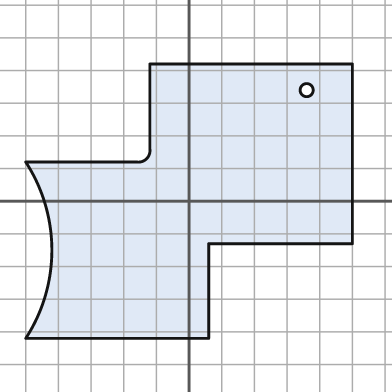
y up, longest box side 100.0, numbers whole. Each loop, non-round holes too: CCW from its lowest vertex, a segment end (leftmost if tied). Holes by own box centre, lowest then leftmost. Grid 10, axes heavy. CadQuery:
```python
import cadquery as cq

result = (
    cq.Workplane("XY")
    .moveTo(-50.0, -42.0)
    .lineTo(6.0, -42.0)
    .lineTo(6.0, -13.0)
    .lineTo(50.0, -13.0)
    .lineTo(50.0, 42.0)
    .lineTo(-12.0, 42.0)
    .lineTo(-12.0, 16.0)
    .threePointArc((-13.0, 13.0), (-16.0, 12.0))
    .lineTo(-50.0, 12.0)
    .threePointArc((-42.0, -15.0), (-50.0, -42.0))
    .close()
    .moveTo(36.0, 34.0)
    .circle(2.0)
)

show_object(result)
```